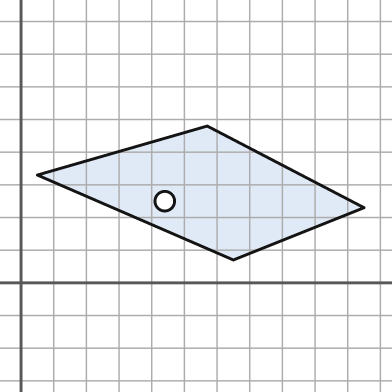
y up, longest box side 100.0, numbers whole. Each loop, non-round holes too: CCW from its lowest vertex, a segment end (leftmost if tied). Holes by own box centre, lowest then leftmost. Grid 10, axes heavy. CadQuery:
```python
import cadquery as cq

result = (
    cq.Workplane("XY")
    .moveTo(65.0, 7.0)
    .lineTo(105.0, 23.0)
    .lineTo(57.0, 48.0)
    .lineTo(5.0, 33.0)
    .close()
    .moveTo(44.0, 25.0)
    .circle(3.0)
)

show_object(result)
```